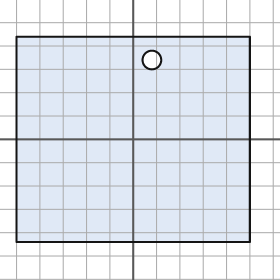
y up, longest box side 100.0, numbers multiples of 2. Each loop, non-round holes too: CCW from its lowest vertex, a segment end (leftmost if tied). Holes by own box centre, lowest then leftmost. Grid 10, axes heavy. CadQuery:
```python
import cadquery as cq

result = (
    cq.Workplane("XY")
    .moveTo(-50.0, -44.0)
    .lineTo(50.0, -44.0)
    .lineTo(50.0, 44.0)
    .lineTo(-50.0, 44.0)
    .close()
    .moveTo(8.0, 34.0)
    .circle(4.0)
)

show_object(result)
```